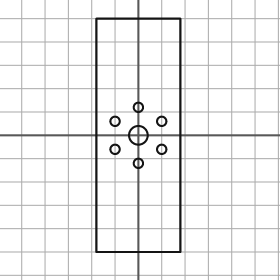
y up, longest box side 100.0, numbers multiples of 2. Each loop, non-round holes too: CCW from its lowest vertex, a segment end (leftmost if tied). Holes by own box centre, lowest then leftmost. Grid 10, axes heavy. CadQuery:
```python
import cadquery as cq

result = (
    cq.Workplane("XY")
    .moveTo(-18.0, -50.0)
    .lineTo(18.0, -50.0)
    .lineTo(18.0, 50.0)
    .lineTo(-18.0, 50.0)
    .close()
    .moveTo(0.0, -12.0)
    .circle(2.0)
    .moveTo(-10.0, -6.0)
    .circle(2.0)
    .moveTo(10.0, -6.0)
    .circle(2.0)
    .moveTo(0.0, 0.0)
    .circle(4.0)
    .moveTo(-10.0, 6.0)
    .circle(2.0)
    .moveTo(10.0, 6.0)
    .circle(2.0)
    .moveTo(0.0, 12.0)
    .circle(2.0)
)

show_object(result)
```